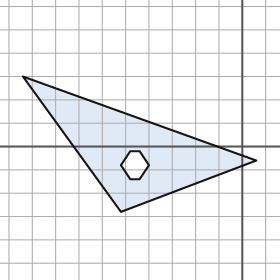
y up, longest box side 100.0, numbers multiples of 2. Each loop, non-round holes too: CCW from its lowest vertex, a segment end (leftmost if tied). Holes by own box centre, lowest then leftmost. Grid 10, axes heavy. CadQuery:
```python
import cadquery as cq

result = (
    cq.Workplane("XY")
    .moveTo(-52.0, -28.0)
    .lineTo(6.0, -6.0)
    .lineTo(-94.0, 30.0)
    .close()
    .moveTo(-48.0, -14.0)
    .lineTo(-44.0, -14.0)
    .lineTo(-40.0, -8.0)
    .lineTo(-44.0, -2.0)
    .lineTo(-48.0, -2.0)
    .lineTo(-52.0, -8.0)
    .close()
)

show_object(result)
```